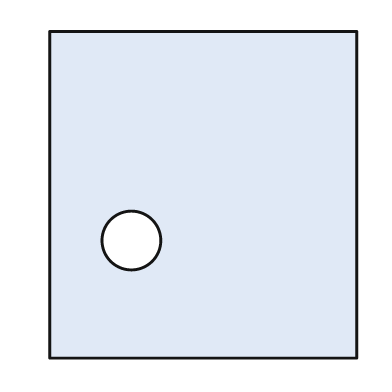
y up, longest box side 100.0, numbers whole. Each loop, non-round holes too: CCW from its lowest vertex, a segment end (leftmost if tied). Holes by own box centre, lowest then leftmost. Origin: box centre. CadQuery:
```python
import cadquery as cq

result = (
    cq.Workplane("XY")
    .moveTo(-47.0, -50.0)
    .lineTo(47.0, -50.0)
    .lineTo(47.0, 50.0)
    .lineTo(-47.0, 50.0)
    .close()
    .moveTo(-22.0, -14.0)
    .circle(9.0)
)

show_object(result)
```